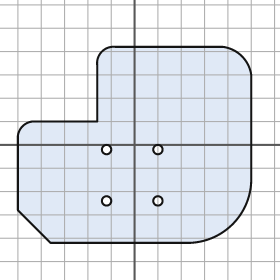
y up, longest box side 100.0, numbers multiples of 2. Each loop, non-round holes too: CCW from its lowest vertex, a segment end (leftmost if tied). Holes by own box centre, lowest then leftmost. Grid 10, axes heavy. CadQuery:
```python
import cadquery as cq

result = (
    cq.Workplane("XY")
    .moveTo(-36.0, -42.0)
    .lineTo(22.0, -42.0)
    .threePointArc((42.0, -34.0), (50.0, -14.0))
    .lineTo(50.0, 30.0)
    .threePointArc((46.0, 38.0), (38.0, 42.0))
    .lineTo(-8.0, 42.0)
    .threePointArc((-14.0, 40.0), (-16.0, 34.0))
    .lineTo(-16.0, 10.0)
    .lineTo(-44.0, 10.0)
    .threePointArc((-48.0, 8.0), (-50.0, 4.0))
    .lineTo(-50.0, -28.0)
    .close()
    .moveTo(-12.0, -24.0)
    .circle(2.0)
    .moveTo(10.0, -24.0)
    .circle(2.0)
    .moveTo(-12.0, -2.0)
    .circle(2.0)
    .moveTo(10.0, -2.0)
    .circle(2.0)
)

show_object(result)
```